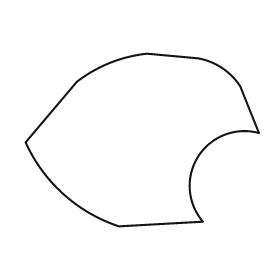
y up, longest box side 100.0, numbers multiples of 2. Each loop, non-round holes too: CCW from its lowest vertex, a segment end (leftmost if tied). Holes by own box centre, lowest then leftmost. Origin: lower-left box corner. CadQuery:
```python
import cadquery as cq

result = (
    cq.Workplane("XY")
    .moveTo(40.0, 0.0)
    .lineTo(76.0, 2.0)
    .threePointArc((74.0, 30.0), (100.0, 40.0))
    .lineTo(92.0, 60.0)
    .threePointArc((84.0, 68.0), (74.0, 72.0))
    .lineTo(52.0, 74.0)
    .threePointArc((36.0, 70.0), (22.0, 62.0))
    .lineTo(0.0, 36.0)
    .threePointArc((16.0, 14.0), (40.0, 0.0))
    .close()
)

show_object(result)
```